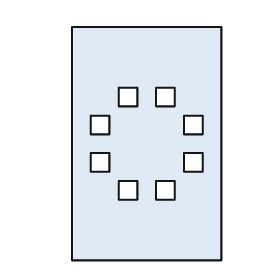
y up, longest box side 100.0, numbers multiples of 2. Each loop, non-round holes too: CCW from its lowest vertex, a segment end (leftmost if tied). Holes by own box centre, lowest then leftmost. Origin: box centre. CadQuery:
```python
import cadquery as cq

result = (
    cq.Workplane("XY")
    .moveTo(-32.0, -50.0)
    .lineTo(32.0, -50.0)
    .lineTo(32.0, 50.0)
    .lineTo(-32.0, 50.0)
    .close()
    .moveTo(-12.0, -24.0)
    .lineTo(-4.0, -24.0)
    .lineTo(-4.0, -16.0)
    .lineTo(-12.0, -16.0)
    .close()
    .moveTo(4.0, -24.0)
    .lineTo(12.0, -24.0)
    .lineTo(12.0, -16.0)
    .lineTo(4.0, -16.0)
    .close()
    .moveTo(-24.0, -12.0)
    .lineTo(-16.0, -12.0)
    .lineTo(-16.0, -4.0)
    .lineTo(-24.0, -4.0)
    .close()
    .moveTo(16.0, -12.0)
    .lineTo(24.0, -12.0)
    .lineTo(24.0, -4.0)
    .lineTo(16.0, -4.0)
    .close()
    .moveTo(-24.0, 4.0)
    .lineTo(-16.0, 4.0)
    .lineTo(-16.0, 12.0)
    .lineTo(-24.0, 12.0)
    .close()
    .moveTo(16.0, 4.0)
    .lineTo(24.0, 4.0)
    .lineTo(24.0, 12.0)
    .lineTo(16.0, 12.0)
    .close()
    .moveTo(-12.0, 16.0)
    .lineTo(-4.0, 16.0)
    .lineTo(-4.0, 24.0)
    .lineTo(-12.0, 24.0)
    .close()
    .moveTo(4.0, 16.0)
    .lineTo(12.0, 16.0)
    .lineTo(12.0, 24.0)
    .lineTo(4.0, 24.0)
    .close()
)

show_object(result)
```